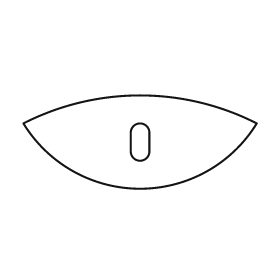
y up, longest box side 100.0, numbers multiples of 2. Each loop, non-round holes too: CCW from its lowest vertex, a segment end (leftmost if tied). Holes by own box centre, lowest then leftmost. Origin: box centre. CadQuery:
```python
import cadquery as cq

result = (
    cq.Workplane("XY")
    .moveTo(-50.0, 8.0)
    .threePointArc((0.0, -20.0), (50.0, 8.0))
    .threePointArc((0.0, 20.0), (-50.0, 8.0))
    .close()
    .moveTo(-4.0, -4.0)
    .threePointArc((0.0, -8.0), (4.0, -4.0))
    .lineTo(4.0, 4.0)
    .threePointArc((0.0, 8.0), (-4.0, 4.0))
    .close()
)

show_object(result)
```